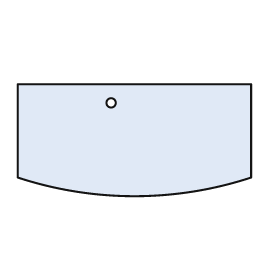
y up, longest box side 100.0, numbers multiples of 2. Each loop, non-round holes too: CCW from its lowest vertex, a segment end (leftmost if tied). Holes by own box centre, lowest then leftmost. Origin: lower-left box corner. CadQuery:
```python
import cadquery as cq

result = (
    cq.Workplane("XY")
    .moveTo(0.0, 8.0)
    .threePointArc((50.0, 0.0), (100.0, 8.0))
    .lineTo(100.0, 48.0)
    .lineTo(0.0, 48.0)
    .close()
    .moveTo(40.0, 40.0)
    .circle(2.0)
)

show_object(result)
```